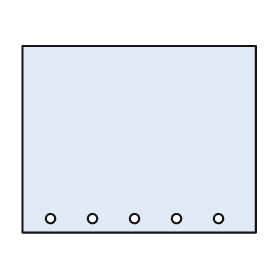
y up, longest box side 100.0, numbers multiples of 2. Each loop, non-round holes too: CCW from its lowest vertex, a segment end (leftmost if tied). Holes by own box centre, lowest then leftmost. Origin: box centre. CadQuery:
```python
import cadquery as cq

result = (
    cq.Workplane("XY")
    .moveTo(-50.0, -40.0)
    .lineTo(50.0, -40.0)
    .lineTo(50.0, 40.0)
    .lineTo(-50.0, 40.0)
    .close()
    .moveTo(-38.0, -34.0)
    .circle(2.0)
    .moveTo(-20.0, -34.0)
    .circle(2.0)
    .moveTo(-2.0, -34.0)
    .circle(2.0)
    .moveTo(16.0, -34.0)
    .circle(2.0)
    .moveTo(34.0, -34.0)
    .circle(2.0)
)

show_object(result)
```